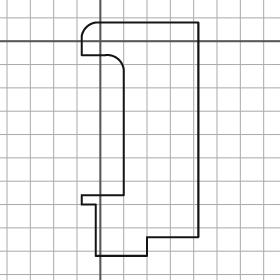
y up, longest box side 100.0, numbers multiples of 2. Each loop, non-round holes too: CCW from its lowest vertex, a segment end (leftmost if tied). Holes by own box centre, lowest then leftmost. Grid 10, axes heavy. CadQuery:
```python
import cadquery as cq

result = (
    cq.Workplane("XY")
    .moveTo(-2.0, -92.0)
    .lineTo(20.0, -92.0)
    .lineTo(20.0, -84.0)
    .lineTo(42.0, -84.0)
    .lineTo(42.0, 8.0)
    .lineTo(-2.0, 8.0)
    .threePointArc((-6.0, 6.0), (-8.0, 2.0))
    .lineTo(-8.0, -6.0)
    .lineTo(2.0, -6.0)
    .threePointArc((8.0, -8.0), (10.0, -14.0))
    .lineTo(10.0, -66.0)
    .lineTo(-8.0, -66.0)
    .lineTo(-8.0, -70.0)
    .lineTo(-2.0, -70.0)
    .close()
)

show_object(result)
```